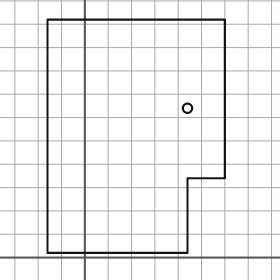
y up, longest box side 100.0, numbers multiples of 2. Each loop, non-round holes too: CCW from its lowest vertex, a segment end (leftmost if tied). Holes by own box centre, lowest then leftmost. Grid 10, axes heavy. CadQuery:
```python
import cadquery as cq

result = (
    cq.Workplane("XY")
    .moveTo(-16.0, 2.0)
    .lineTo(44.0, 2.0)
    .lineTo(44.0, 34.0)
    .lineTo(60.0, 34.0)
    .lineTo(60.0, 102.0)
    .lineTo(-16.0, 102.0)
    .close()
    .moveTo(44.0, 64.0)
    .circle(2.0)
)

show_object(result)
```